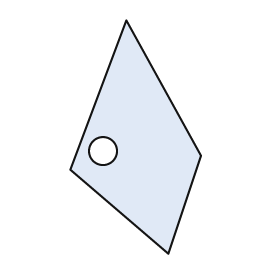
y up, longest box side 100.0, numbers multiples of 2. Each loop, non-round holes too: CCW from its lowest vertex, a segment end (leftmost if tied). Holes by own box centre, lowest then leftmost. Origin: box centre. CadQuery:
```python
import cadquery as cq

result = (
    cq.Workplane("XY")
    .moveTo(14.0, -50.0)
    .lineTo(28.0, -8.0)
    .lineTo(-4.0, 50.0)
    .lineTo(-28.0, -14.0)
    .close()
    .moveTo(-14.0, -6.0)
    .circle(6.0)
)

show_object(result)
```